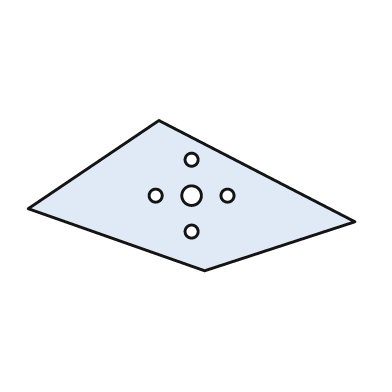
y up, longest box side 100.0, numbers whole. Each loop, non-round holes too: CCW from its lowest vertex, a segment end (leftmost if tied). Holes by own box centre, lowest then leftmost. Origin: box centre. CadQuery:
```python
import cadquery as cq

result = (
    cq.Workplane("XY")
    .moveTo(4.0, -23.0)
    .lineTo(50.0, -8.0)
    .lineTo(-10.0, 23.0)
    .lineTo(-50.0, -4.0)
    .close()
    .moveTo(0.0, -11.0)
    .circle(2.0)
    .moveTo(-11.0, 0.0)
    .circle(2.0)
    .moveTo(0.0, 0.0)
    .circle(3.0)
    .moveTo(11.0, 0.0)
    .circle(2.0)
    .moveTo(0.0, 11.0)
    .circle(2.0)
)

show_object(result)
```